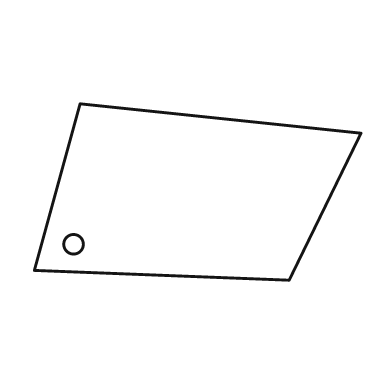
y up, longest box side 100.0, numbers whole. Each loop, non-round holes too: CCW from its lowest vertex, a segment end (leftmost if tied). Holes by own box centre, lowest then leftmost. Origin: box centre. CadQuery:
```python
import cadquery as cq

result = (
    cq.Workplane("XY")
    .moveTo(28.0, -27.0)
    .lineTo(50.0, 18.0)
    .lineTo(-36.0, 27.0)
    .lineTo(-50.0, -24.0)
    .close()
    .moveTo(-38.0, -16.0)
    .circle(3.0)
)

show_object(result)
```